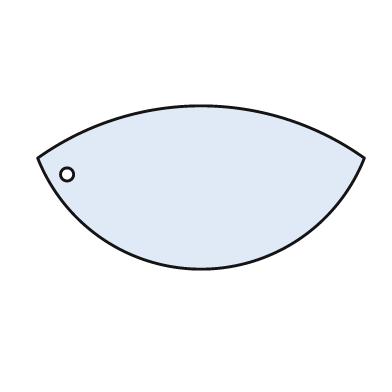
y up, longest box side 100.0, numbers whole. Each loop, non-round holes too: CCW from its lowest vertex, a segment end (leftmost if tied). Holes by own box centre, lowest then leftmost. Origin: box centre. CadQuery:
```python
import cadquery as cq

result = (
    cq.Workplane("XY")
    .moveTo(-50.0, 9.0)
    .threePointArc((0.0, -25.0), (50.0, 9.0))
    .threePointArc((0.0, 25.0), (-50.0, 9.0))
    .close()
    .moveTo(-41.0, 4.0)
    .circle(2.0)
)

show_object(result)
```